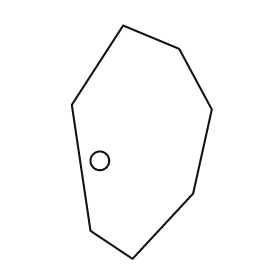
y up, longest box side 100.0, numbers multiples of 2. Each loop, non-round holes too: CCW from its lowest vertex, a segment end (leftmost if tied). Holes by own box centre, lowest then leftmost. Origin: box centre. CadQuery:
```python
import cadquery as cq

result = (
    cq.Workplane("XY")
    .moveTo(-4.0, -50.0)
    .lineTo(22.0, -22.0)
    .lineTo(30.0, 14.0)
    .lineTo(16.0, 40.0)
    .lineTo(-8.0, 50.0)
    .lineTo(-30.0, 16.0)
    .lineTo(-22.0, -38.0)
    .close()
    .moveTo(-18.0, -8.0)
    .circle(4.0)
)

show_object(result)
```